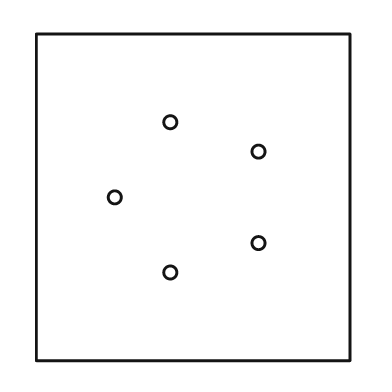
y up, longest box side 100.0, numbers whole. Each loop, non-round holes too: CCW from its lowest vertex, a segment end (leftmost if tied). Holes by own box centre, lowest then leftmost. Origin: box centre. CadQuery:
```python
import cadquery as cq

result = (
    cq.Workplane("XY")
    .moveTo(-48.0, -50.0)
    .lineTo(48.0, -50.0)
    .lineTo(48.0, 50.0)
    .lineTo(-48.0, 50.0)
    .close()
    .moveTo(-7.0, -23.0)
    .circle(2.0)
    .moveTo(20.0, -14.0)
    .circle(2.0)
    .moveTo(-24.0, 0.0)
    .circle(2.0)
    .moveTo(20.0, 14.0)
    .circle(2.0)
    .moveTo(-7.0, 23.0)
    .circle(2.0)
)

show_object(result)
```